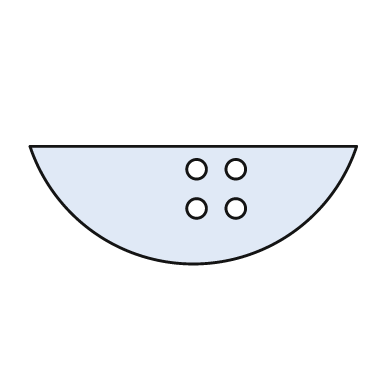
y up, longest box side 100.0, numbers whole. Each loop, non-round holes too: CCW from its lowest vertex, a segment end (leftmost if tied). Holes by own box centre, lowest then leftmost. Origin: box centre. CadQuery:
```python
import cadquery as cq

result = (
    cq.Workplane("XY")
    .moveTo(-50.0, 18.0)
    .threePointArc((0.0, -18.0), (50.0, 18.0))
    .close()
    .moveTo(1.0, -1.0)
    .circle(3.0)
    .moveTo(13.0, -1.0)
    .circle(3.0)
    .moveTo(1.0, 11.0)
    .circle(3.0)
    .moveTo(13.0, 11.0)
    .circle(3.0)
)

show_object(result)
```